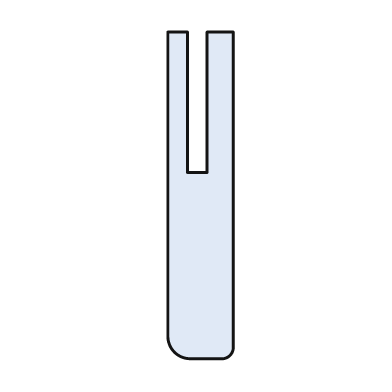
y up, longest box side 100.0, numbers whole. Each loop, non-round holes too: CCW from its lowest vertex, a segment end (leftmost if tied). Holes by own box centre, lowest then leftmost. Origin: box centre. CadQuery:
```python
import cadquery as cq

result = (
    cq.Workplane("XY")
    .moveTo(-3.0, -50.0)
    .lineTo(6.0, -50.0)
    .threePointArc((9.0, -49.0), (10.0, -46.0))
    .lineTo(10.0, 50.0)
    .lineTo(2.0, 50.0)
    .lineTo(2.0, 7.0)
    .lineTo(-4.0, 7.0)
    .lineTo(-4.0, 50.0)
    .lineTo(-10.0, 50.0)
    .lineTo(-10.0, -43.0)
    .threePointArc((-8.0, -48.0), (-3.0, -50.0))
    .close()
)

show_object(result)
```